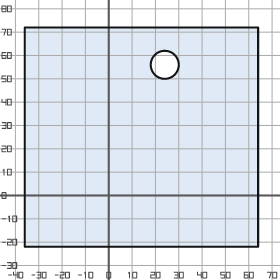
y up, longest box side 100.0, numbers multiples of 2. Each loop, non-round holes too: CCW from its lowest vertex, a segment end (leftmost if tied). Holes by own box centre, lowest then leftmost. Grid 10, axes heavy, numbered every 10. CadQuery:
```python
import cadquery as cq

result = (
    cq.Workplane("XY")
    .moveTo(-36.0, -22.0)
    .lineTo(64.0, -22.0)
    .lineTo(64.0, 72.0)
    .lineTo(-36.0, 72.0)
    .close()
    .moveTo(24.0, 56.0)
    .circle(6.0)
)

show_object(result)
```